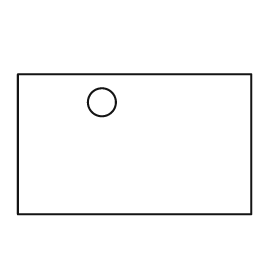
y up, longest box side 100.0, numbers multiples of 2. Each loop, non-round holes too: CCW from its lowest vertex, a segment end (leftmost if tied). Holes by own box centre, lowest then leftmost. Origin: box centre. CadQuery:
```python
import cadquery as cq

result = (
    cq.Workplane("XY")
    .moveTo(-50.0, -30.0)
    .lineTo(50.0, -30.0)
    .lineTo(50.0, 30.0)
    .lineTo(-50.0, 30.0)
    .close()
    .moveTo(-14.0, 18.0)
    .circle(6.0)
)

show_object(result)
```